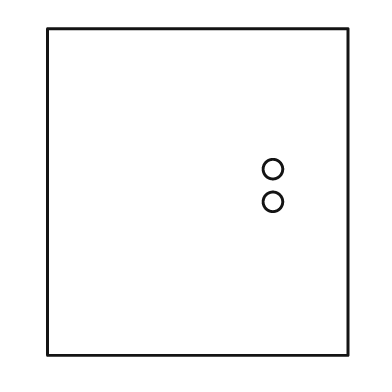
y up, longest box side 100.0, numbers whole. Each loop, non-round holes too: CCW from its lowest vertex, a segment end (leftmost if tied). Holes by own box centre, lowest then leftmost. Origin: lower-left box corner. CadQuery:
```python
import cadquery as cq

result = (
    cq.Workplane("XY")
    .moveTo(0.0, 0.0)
    .lineTo(92.0, 0.0)
    .lineTo(92.0, 100.0)
    .lineTo(0.0, 100.0)
    .close()
    .moveTo(69.0, 47.0)
    .circle(3.0)
    .moveTo(69.0, 57.0)
    .circle(3.0)
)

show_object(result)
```